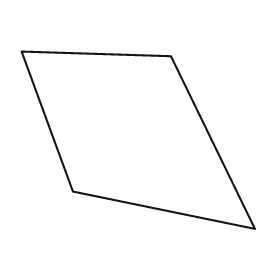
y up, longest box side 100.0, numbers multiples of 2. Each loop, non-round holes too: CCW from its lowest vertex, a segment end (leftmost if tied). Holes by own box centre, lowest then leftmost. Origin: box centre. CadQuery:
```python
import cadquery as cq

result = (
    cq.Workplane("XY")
    .moveTo(50.0, -38.0)
    .lineTo(14.0, 36.0)
    .lineTo(-50.0, 38.0)
    .lineTo(-28.0, -22.0)
    .close()
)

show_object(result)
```